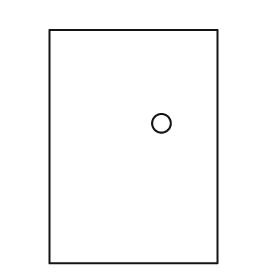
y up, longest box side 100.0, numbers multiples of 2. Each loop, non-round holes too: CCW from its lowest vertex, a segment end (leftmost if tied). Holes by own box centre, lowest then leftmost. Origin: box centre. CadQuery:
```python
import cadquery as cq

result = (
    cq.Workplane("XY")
    .moveTo(-36.0, -50.0)
    .lineTo(36.0, -50.0)
    .lineTo(36.0, 50.0)
    .lineTo(-36.0, 50.0)
    .close()
    .moveTo(12.0, 10.0)
    .circle(4.0)
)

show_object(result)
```